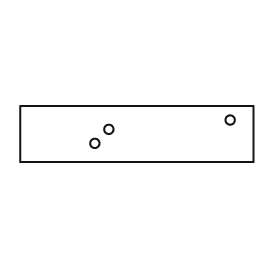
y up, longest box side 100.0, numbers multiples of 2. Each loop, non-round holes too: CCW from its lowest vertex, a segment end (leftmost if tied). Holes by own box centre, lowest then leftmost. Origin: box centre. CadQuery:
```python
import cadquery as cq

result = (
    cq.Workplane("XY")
    .moveTo(-50.0, -12.0)
    .lineTo(50.0, -12.0)
    .lineTo(50.0, 12.0)
    .lineTo(-50.0, 12.0)
    .close()
    .moveTo(-18.0, -4.0)
    .circle(2.0)
    .moveTo(-12.0, 2.0)
    .circle(2.0)
    .moveTo(40.0, 6.0)
    .circle(2.0)
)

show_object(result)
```